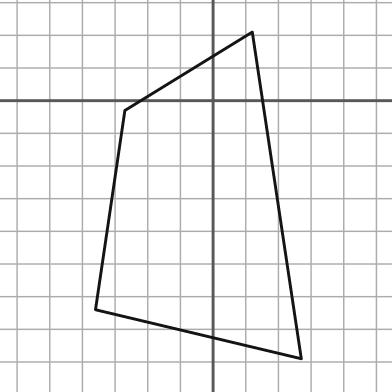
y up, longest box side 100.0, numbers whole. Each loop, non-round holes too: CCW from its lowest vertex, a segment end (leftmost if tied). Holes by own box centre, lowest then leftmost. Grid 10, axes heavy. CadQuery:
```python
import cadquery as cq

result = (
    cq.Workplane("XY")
    .moveTo(27.0, -79.0)
    .lineTo(12.0, 21.0)
    .lineTo(-27.0, -3.0)
    .lineTo(-36.0, -64.0)
    .close()
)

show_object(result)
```